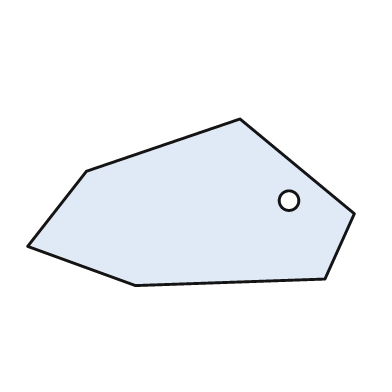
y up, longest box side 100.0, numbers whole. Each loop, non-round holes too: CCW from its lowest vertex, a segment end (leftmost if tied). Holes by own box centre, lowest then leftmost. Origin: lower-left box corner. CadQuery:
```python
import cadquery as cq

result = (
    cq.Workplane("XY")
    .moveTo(33.0, 0.0)
    .lineTo(91.0, 2.0)
    .lineTo(100.0, 22.0)
    .lineTo(65.0, 51.0)
    .lineTo(18.0, 35.0)
    .lineTo(0.0, 12.0)
    .close()
    .moveTo(80.0, 26.0)
    .circle(3.0)
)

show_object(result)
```